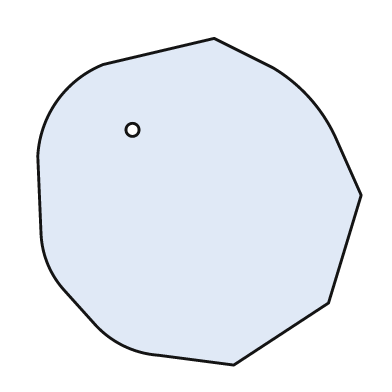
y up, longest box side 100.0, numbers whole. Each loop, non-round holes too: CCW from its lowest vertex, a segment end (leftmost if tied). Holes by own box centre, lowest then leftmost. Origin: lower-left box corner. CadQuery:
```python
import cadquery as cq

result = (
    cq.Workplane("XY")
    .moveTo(60.0, 0.0)
    .lineTo(89.0, 19.0)
    .lineTo(99.0, 52.0)
    .lineTo(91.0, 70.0)
    .threePointArc((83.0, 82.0), (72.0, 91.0))
    .lineTo(54.0, 100.0)
    .lineTo(20.0, 92.0)
    .threePointArc((6.0, 81.0), (0.0, 64.0))
    .lineTo(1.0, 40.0)
    .threePointArc((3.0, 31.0), (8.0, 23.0))
    .lineTo(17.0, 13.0)
    .threePointArc((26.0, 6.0), (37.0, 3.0))
    .close()
    .moveTo(29.0, 72.0)
    .circle(2.0)
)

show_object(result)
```